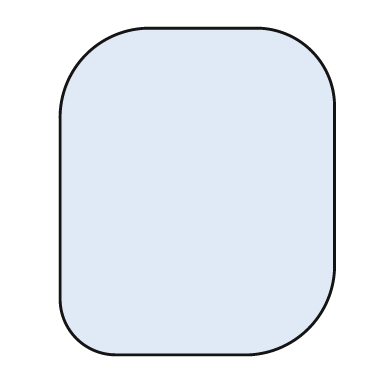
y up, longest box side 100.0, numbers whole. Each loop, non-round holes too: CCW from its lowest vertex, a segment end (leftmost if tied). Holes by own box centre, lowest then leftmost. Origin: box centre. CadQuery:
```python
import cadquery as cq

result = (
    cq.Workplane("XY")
    .moveTo(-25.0, -50.0)
    .lineTo(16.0, -50.0)
    .threePointArc((34.0, -42.0), (42.0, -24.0))
    .lineTo(42.0, 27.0)
    .threePointArc((35.0, 43.0), (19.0, 50.0))
    .lineTo(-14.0, 50.0)
    .threePointArc((-34.0, 42.0), (-42.0, 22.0))
    .lineTo(-42.0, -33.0)
    .threePointArc((-37.0, -45.0), (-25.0, -50.0))
    .close()
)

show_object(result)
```